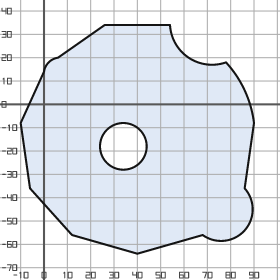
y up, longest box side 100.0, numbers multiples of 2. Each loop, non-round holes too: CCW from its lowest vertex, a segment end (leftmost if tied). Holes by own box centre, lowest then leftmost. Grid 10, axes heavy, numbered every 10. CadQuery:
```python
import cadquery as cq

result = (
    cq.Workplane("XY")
    .moveTo(40.0, -64.0)
    .lineTo(68.0, -56.0)
    .threePointArc((86.0, -54.0), (86.0, -36.0))
    .lineTo(90.0, -8.0)
    .threePointArc((86.0, 6.0), (78.0, 18.0))
    .threePointArc((62.0, 20.0), (54.0, 34.0))
    .lineTo(26.0, 34.0)
    .lineTo(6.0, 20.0)
    .threePointArc((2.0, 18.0), (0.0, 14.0))
    .lineTo(-10.0, -8.0)
    .lineTo(-6.0, -36.0)
    .lineTo(12.0, -56.0)
    .close()
    .moveTo(34.0, -18.0)
    .circle(10.0)
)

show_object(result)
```